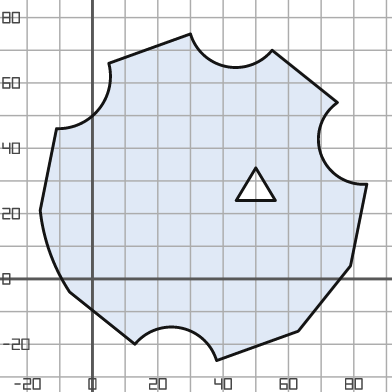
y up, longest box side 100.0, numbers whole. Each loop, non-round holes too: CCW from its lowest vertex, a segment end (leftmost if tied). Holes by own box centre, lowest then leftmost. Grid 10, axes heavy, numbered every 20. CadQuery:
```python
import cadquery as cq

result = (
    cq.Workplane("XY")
    .moveTo(38.0, -25.0)
    .lineTo(63.0, -16.0)
    .lineTo(79.0, 4.0)
    .lineTo(84.0, 29.0)
    .threePointArc((70.0, 38.0), (75.0, 54.0))
    .lineTo(55.0, 70.0)
    .threePointArc((41.0, 65.0), (30.0, 75.0))
    .lineTo(5.0, 66.0)
    .threePointArc((2.0, 52.0), (-11.0, 46.0))
    .lineTo(-16.0, 21.0)
    .threePointArc((-13.0, 8.0), (-7.0, -4.0))
    .lineTo(13.0, -20.0)
    .threePointArc((27.0, -15.0), (38.0, -25.0))
    .close()
    .moveTo(44.0, 24.0)
    .lineTo(56.0, 24.0)
    .lineTo(50.0, 34.0)
    .close()
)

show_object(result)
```